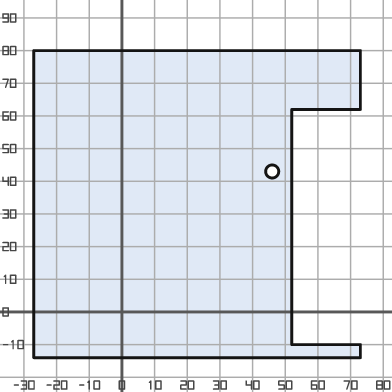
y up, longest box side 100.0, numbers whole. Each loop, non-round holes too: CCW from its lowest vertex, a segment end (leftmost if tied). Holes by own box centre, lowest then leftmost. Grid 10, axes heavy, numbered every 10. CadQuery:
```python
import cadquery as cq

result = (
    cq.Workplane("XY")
    .moveTo(-27.0, -14.0)
    .lineTo(73.0, -14.0)
    .lineTo(73.0, -10.0)
    .lineTo(52.0, -10.0)
    .lineTo(52.0, 62.0)
    .lineTo(73.0, 62.0)
    .lineTo(73.0, 80.0)
    .lineTo(-27.0, 80.0)
    .close()
    .moveTo(46.0, 43.0)
    .circle(2.0)
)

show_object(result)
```